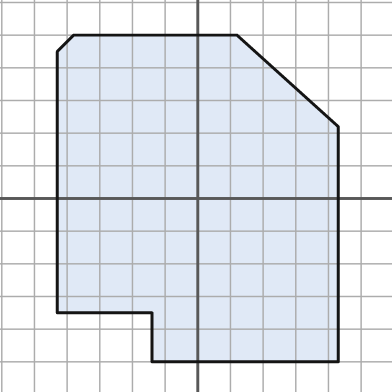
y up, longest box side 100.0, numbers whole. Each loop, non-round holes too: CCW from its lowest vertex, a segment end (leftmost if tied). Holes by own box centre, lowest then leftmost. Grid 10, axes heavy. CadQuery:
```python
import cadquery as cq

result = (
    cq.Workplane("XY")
    .moveTo(-14.0, -50.0)
    .lineTo(43.0, -50.0)
    .lineTo(43.0, 22.0)
    .lineTo(12.0, 50.0)
    .lineTo(-38.0, 50.0)
    .lineTo(-43.0, 45.0)
    .lineTo(-43.0, -35.0)
    .lineTo(-14.0, -35.0)
    .close()
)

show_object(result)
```